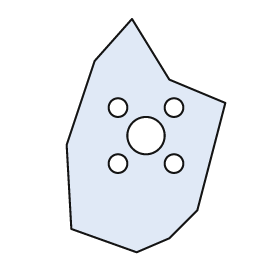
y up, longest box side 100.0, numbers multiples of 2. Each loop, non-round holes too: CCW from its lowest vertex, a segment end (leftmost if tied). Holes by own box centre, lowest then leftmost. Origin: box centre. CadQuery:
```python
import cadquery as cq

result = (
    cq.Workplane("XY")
    .moveTo(-4.0, -50.0)
    .lineTo(10.0, -44.0)
    .lineTo(22.0, -32.0)
    .lineTo(34.0, 14.0)
    .lineTo(10.0, 24.0)
    .lineTo(-6.0, 50.0)
    .lineTo(-22.0, 32.0)
    .lineTo(-34.0, -4.0)
    .lineTo(-32.0, -40.0)
    .close()
    .moveTo(-12.0, -12.0)
    .circle(4.0)
    .moveTo(12.0, -12.0)
    .circle(4.0)
    .moveTo(0.0, 0.0)
    .circle(8.0)
    .moveTo(-12.0, 12.0)
    .circle(4.0)
    .moveTo(12.0, 12.0)
    .circle(4.0)
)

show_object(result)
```